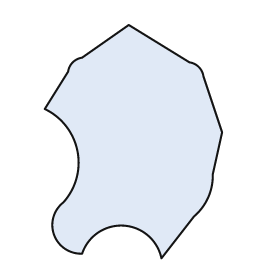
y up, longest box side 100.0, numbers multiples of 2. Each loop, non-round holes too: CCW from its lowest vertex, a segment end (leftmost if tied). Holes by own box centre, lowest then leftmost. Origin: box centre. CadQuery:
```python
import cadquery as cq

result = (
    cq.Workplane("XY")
    .moveTo(12.0, -50.0)
    .lineTo(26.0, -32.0)
    .threePointArc((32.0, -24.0), (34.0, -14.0))
    .lineTo(38.0, 4.0)
    .lineTo(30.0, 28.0)
    .threePointArc((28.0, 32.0), (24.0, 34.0))
    .lineTo(-2.0, 50.0)
    .lineTo(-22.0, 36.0)
    .threePointArc((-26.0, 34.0), (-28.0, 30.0))
    .lineTo(-38.0, 14.0)
    .threePointArc((-24.0, -4.0), (-30.0, -26.0))
    .threePointArc((-34.0, -40.0), (-22.0, -48.0))
    .threePointArc((-4.0, -36.0), (12.0, -50.0))
    .close()
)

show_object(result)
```